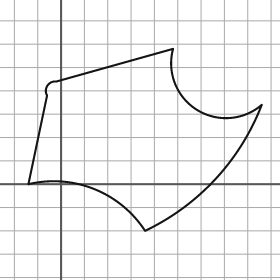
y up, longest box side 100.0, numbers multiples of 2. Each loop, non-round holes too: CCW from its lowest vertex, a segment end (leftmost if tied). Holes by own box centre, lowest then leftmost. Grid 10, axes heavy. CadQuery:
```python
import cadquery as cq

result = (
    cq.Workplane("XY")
    .moveTo(36.0, -20.0)
    .threePointArc((66.0, 2.0), (86.0, 34.0))
    .threePointArc((58.0, 32.0), (48.0, 58.0))
    .lineTo(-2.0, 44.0)
    .threePointArc((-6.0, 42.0), (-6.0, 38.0))
    .lineTo(-14.0, 0.0)
    .threePointArc((14.0, -2.0), (36.0, -20.0))
    .close()
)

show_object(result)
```